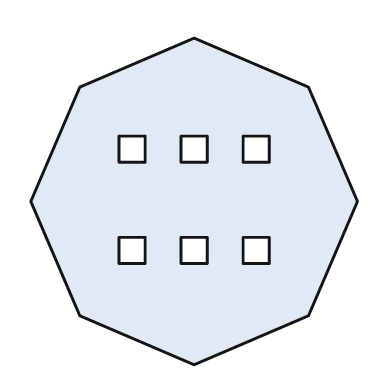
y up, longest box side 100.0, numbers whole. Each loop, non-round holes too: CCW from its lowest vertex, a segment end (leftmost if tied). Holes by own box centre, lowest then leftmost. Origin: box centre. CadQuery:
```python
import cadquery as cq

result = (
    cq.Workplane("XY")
    .moveTo(0.0, -50.0)
    .lineTo(35.0, -35.0)
    .lineTo(50.0, 0.0)
    .lineTo(35.0, 35.0)
    .lineTo(0.0, 50.0)
    .lineTo(-35.0, 35.0)
    .lineTo(-50.0, 0.0)
    .lineTo(-35.0, -35.0)
    .close()
    .moveTo(-23.0, -19.0)
    .lineTo(-15.0, -19.0)
    .lineTo(-15.0, -11.0)
    .lineTo(-23.0, -11.0)
    .close()
    .moveTo(-4.0, -19.0)
    .lineTo(4.0, -19.0)
    .lineTo(4.0, -11.0)
    .lineTo(-4.0, -11.0)
    .close()
    .moveTo(15.0, -19.0)
    .lineTo(23.0, -19.0)
    .lineTo(23.0, -11.0)
    .lineTo(15.0, -11.0)
    .close()
    .moveTo(-23.0, 12.0)
    .lineTo(-15.0, 12.0)
    .lineTo(-15.0, 20.0)
    .lineTo(-23.0, 20.0)
    .close()
    .moveTo(-4.0, 12.0)
    .lineTo(4.0, 12.0)
    .lineTo(4.0, 20.0)
    .lineTo(-4.0, 20.0)
    .close()
    .moveTo(15.0, 12.0)
    .lineTo(23.0, 12.0)
    .lineTo(23.0, 20.0)
    .lineTo(15.0, 20.0)
    .close()
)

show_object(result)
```